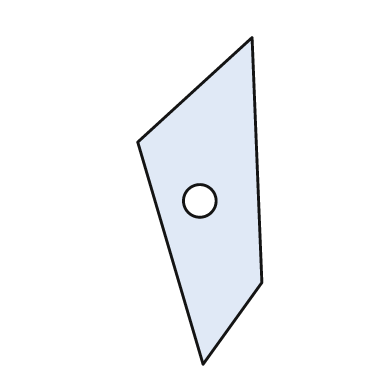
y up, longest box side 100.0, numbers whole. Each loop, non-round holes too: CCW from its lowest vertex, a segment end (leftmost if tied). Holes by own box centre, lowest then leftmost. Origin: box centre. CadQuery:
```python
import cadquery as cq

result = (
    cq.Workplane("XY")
    .moveTo(1.0, -50.0)
    .lineTo(19.0, -25.0)
    .lineTo(16.0, 50.0)
    .lineTo(-19.0, 18.0)
    .close()
    .moveTo(0.0, 0.0)
    .circle(5.0)
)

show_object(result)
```